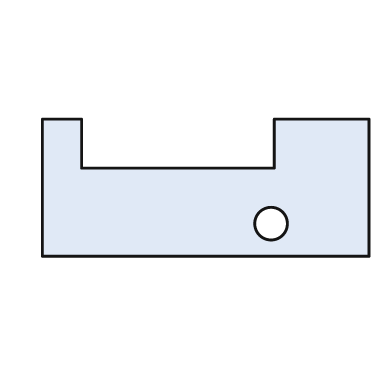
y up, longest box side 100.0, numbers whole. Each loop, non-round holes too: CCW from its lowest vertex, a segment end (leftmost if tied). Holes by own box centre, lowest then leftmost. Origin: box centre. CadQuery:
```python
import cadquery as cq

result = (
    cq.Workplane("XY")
    .moveTo(-50.0, -21.0)
    .lineTo(50.0, -21.0)
    .lineTo(50.0, 21.0)
    .lineTo(21.0, 21.0)
    .lineTo(21.0, 6.0)
    .lineTo(-38.0, 6.0)
    .lineTo(-38.0, 21.0)
    .lineTo(-50.0, 21.0)
    .close()
    .moveTo(20.0, -11.0)
    .circle(5.0)
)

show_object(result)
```